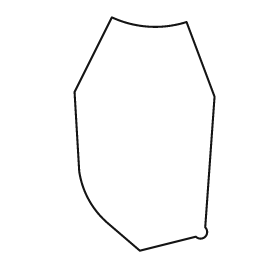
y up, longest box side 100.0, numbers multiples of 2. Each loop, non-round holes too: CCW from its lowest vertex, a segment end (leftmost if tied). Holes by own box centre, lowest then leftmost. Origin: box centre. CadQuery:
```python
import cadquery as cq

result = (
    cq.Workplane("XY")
    .moveTo(-2.0, -50.0)
    .lineTo(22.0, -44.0)
    .threePointArc((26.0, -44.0), (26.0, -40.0))
    .lineTo(30.0, 16.0)
    .lineTo(18.0, 48.0)
    .threePointArc((2.0, 46.0), (-14.0, 50.0))
    .lineTo(-30.0, 18.0)
    .lineTo(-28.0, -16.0)
    .threePointArc((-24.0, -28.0), (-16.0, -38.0))
    .close()
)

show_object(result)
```